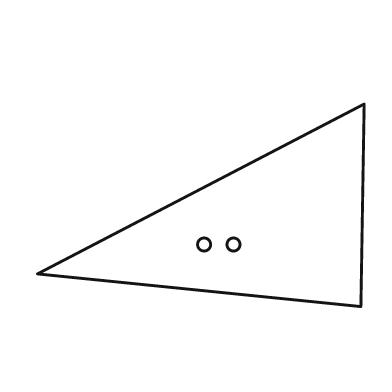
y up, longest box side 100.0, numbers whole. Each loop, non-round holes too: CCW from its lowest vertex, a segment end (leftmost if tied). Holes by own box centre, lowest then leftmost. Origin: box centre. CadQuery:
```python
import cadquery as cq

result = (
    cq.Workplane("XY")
    .moveTo(49.0, -31.0)
    .lineTo(50.0, 31.0)
    .lineTo(-50.0, -21.0)
    .close()
    .moveTo(1.0, -12.0)
    .circle(2.0)
    .moveTo(10.0, -12.0)
    .circle(2.0)
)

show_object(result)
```